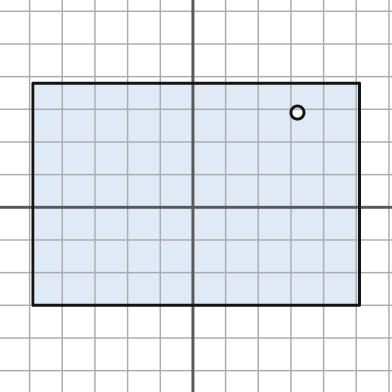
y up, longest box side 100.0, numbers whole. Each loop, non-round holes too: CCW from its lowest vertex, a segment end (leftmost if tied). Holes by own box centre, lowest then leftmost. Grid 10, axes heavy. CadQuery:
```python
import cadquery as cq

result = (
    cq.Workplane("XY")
    .moveTo(-49.0, -30.0)
    .lineTo(51.0, -30.0)
    .lineTo(51.0, 38.0)
    .lineTo(-49.0, 38.0)
    .close()
    .moveTo(32.0, 29.0)
    .circle(2.0)
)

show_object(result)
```